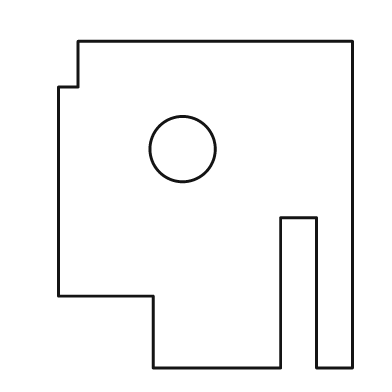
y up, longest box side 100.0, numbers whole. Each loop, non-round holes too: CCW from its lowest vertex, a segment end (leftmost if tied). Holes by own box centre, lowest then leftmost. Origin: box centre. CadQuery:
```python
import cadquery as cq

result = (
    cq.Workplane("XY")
    .moveTo(-16.0, -50.0)
    .lineTo(23.0, -50.0)
    .lineTo(23.0, -4.0)
    .lineTo(34.0, -4.0)
    .lineTo(34.0, -50.0)
    .lineTo(45.0, -50.0)
    .lineTo(45.0, 50.0)
    .lineTo(-39.0, 50.0)
    .lineTo(-39.0, 36.0)
    .lineTo(-45.0, 36.0)
    .lineTo(-45.0, -28.0)
    .lineTo(-16.0, -28.0)
    .close()
    .moveTo(-7.0, 17.0)
    .circle(10.0)
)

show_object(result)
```